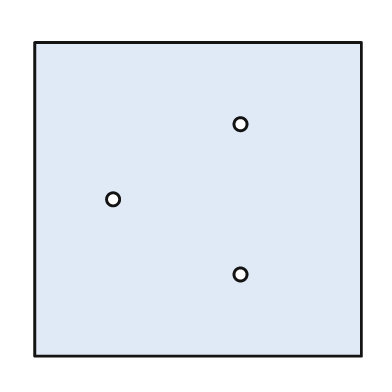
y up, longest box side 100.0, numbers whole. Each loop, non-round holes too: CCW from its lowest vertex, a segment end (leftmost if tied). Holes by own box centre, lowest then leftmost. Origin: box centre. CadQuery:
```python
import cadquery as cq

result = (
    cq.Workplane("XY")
    .moveTo(-50.0, -48.0)
    .lineTo(50.0, -48.0)
    .lineTo(50.0, 48.0)
    .lineTo(-50.0, 48.0)
    .close()
    .moveTo(13.0, -23.0)
    .circle(2.0)
    .moveTo(-26.0, 0.0)
    .circle(2.0)
    .moveTo(13.0, 23.0)
    .circle(2.0)
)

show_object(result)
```